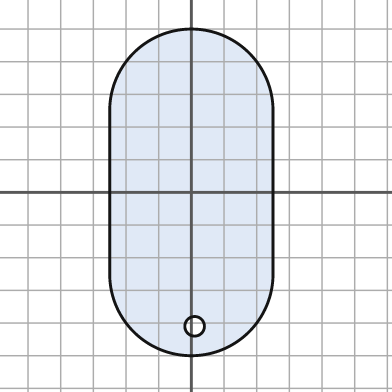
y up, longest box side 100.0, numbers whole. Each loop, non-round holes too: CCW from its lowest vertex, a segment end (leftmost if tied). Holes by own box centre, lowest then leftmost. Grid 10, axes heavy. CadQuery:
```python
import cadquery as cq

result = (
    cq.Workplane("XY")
    .moveTo(-25.0, -25.0)
    .threePointArc((0.0, -50.0), (25.0, -25.0))
    .lineTo(25.0, 25.0)
    .threePointArc((0.0, 50.0), (-25.0, 25.0))
    .close()
    .moveTo(1.0, -41.0)
    .circle(3.0)
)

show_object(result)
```